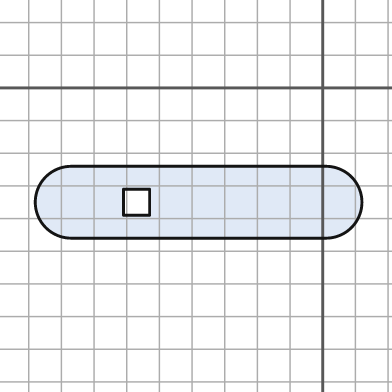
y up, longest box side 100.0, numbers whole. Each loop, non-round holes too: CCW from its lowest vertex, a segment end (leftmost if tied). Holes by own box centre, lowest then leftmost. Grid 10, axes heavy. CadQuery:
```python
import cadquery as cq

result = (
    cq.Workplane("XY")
    .moveTo(-77.0, -46.0)
    .lineTo(1.0, -46.0)
    .threePointArc((12.0, -35.0), (1.0, -24.0))
    .lineTo(-77.0, -24.0)
    .threePointArc((-88.0, -35.0), (-77.0, -46.0))
    .close()
    .moveTo(-61.0, -39.0)
    .lineTo(-53.0, -39.0)
    .lineTo(-53.0, -31.0)
    .lineTo(-61.0, -31.0)
    .close()
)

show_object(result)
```